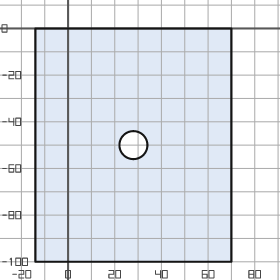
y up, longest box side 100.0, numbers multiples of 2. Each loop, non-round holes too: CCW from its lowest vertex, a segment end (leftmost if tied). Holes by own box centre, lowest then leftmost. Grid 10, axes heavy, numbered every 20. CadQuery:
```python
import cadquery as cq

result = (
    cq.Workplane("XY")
    .moveTo(-14.0, -100.0)
    .lineTo(70.0, -100.0)
    .lineTo(70.0, 0.0)
    .lineTo(-14.0, 0.0)
    .close()
    .moveTo(28.0, -50.0)
    .circle(6.0)
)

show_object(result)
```